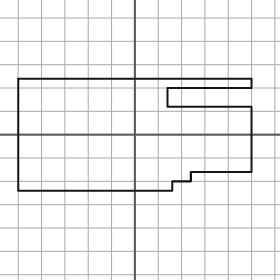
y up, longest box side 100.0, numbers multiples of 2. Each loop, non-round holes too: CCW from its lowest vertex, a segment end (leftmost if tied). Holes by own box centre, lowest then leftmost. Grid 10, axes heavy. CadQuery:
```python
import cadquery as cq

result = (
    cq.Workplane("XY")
    .moveTo(-50.0, -24.0)
    .lineTo(16.0, -24.0)
    .lineTo(16.0, -20.0)
    .lineTo(24.0, -20.0)
    .lineTo(24.0, -16.0)
    .lineTo(50.0, -16.0)
    .lineTo(50.0, 12.0)
    .lineTo(14.0, 12.0)
    .lineTo(14.0, 20.0)
    .lineTo(50.0, 20.0)
    .lineTo(50.0, 24.0)
    .lineTo(-50.0, 24.0)
    .close()
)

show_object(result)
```